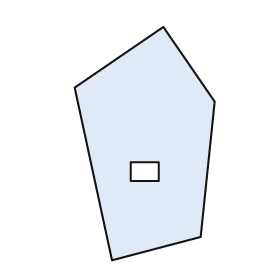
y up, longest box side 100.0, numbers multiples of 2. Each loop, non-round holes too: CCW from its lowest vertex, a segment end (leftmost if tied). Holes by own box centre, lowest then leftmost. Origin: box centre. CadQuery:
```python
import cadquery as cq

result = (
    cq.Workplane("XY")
    .moveTo(-14.0, -50.0)
    .lineTo(24.0, -40.0)
    .lineTo(30.0, 18.0)
    .lineTo(8.0, 50.0)
    .lineTo(-30.0, 24.0)
    .close()
    .moveTo(-6.0, -16.0)
    .lineTo(6.0, -16.0)
    .lineTo(6.0, -8.0)
    .lineTo(-6.0, -8.0)
    .close()
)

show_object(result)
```